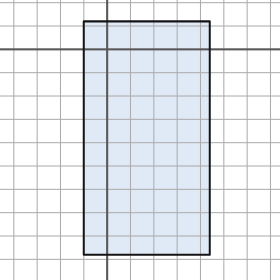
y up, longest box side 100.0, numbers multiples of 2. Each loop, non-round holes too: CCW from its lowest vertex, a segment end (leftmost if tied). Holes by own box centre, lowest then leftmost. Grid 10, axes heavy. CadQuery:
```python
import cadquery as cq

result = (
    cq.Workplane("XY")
    .moveTo(-10.0, -88.0)
    .lineTo(44.0, -88.0)
    .lineTo(44.0, 12.0)
    .lineTo(-10.0, 12.0)
    .close()
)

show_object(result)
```